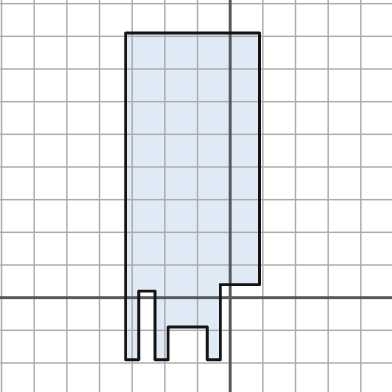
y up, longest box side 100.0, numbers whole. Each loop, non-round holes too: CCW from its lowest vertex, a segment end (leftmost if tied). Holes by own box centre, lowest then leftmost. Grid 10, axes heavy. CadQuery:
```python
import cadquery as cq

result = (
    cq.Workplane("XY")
    .moveTo(-32.0, -19.0)
    .lineTo(-28.0, -19.0)
    .lineTo(-28.0, 2.0)
    .lineTo(-23.0, 2.0)
    .lineTo(-23.0, -19.0)
    .lineTo(-19.0, -19.0)
    .lineTo(-19.0, -9.0)
    .lineTo(-7.0, -9.0)
    .lineTo(-7.0, -19.0)
    .lineTo(-3.0, -19.0)
    .lineTo(-3.0, 4.0)
    .lineTo(9.0, 4.0)
    .lineTo(9.0, 81.0)
    .lineTo(-32.0, 81.0)
    .close()
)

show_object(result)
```